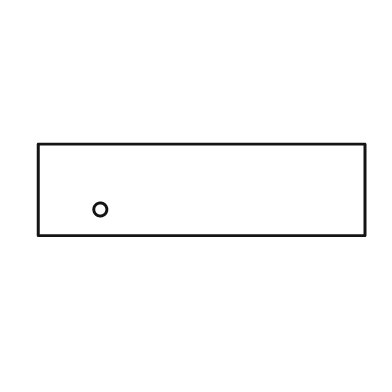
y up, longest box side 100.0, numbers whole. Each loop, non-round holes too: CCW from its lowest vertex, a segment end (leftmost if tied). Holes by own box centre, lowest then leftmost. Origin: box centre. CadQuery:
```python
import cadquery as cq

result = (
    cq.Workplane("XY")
    .moveTo(-50.0, -14.0)
    .lineTo(50.0, -14.0)
    .lineTo(50.0, 14.0)
    .lineTo(-50.0, 14.0)
    .close()
    .moveTo(-31.0, -6.0)
    .circle(2.0)
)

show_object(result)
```